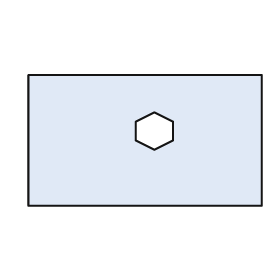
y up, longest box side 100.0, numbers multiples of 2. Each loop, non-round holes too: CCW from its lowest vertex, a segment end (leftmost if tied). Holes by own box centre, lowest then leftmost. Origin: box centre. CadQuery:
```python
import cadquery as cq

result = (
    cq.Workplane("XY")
    .moveTo(-50.0, -28.0)
    .lineTo(50.0, -28.0)
    .lineTo(50.0, 28.0)
    .lineTo(-50.0, 28.0)
    .close()
    .moveTo(4.0, -4.0)
    .lineTo(12.0, 0.0)
    .lineTo(12.0, 8.0)
    .lineTo(4.0, 12.0)
    .lineTo(-4.0, 8.0)
    .lineTo(-4.0, 0.0)
    .close()
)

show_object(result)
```